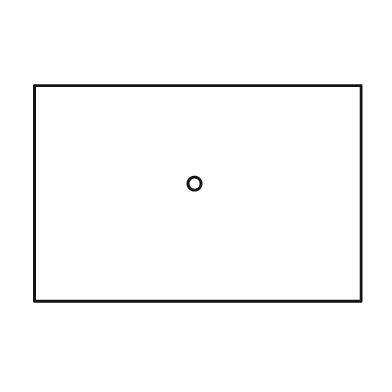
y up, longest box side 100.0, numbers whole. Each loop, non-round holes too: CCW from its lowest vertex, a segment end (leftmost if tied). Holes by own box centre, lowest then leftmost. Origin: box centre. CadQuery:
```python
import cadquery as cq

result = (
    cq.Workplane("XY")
    .moveTo(-50.0, -33.0)
    .lineTo(50.0, -33.0)
    .lineTo(50.0, 33.0)
    .lineTo(-50.0, 33.0)
    .close()
    .moveTo(-1.0, 3.0)
    .circle(2.0)
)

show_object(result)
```